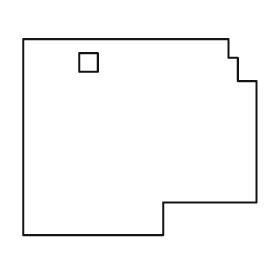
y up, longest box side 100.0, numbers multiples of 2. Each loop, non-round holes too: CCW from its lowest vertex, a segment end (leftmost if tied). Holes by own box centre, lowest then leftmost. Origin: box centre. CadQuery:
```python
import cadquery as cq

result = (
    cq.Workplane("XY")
    .moveTo(-50.0, -42.0)
    .lineTo(10.0, -42.0)
    .lineTo(10.0, -28.0)
    .lineTo(50.0, -28.0)
    .lineTo(50.0, 24.0)
    .lineTo(42.0, 24.0)
    .lineTo(42.0, 34.0)
    .lineTo(38.0, 34.0)
    .lineTo(38.0, 42.0)
    .lineTo(-50.0, 42.0)
    .close()
    .moveTo(-26.0, 28.0)
    .lineTo(-18.0, 28.0)
    .lineTo(-18.0, 36.0)
    .lineTo(-26.0, 36.0)
    .close()
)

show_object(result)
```